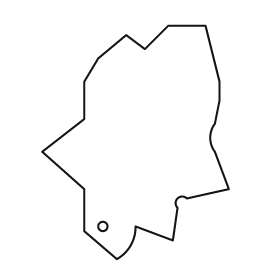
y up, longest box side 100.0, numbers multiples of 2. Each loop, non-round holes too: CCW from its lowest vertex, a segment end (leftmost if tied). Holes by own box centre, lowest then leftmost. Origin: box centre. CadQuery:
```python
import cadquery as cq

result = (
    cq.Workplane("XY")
    .moveTo(-8.0, -50.0)
    .threePointArc((-2.0, -44.0), (0.0, -36.0))
    .lineTo(16.0, -42.0)
    .lineTo(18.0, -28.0)
    .threePointArc((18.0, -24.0), (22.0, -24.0))
    .lineTo(40.0, -20.0)
    .lineTo(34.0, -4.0)
    .threePointArc((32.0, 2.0), (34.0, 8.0))
    .lineTo(36.0, 18.0)
    .lineTo(36.0, 26.0)
    .lineTo(30.0, 50.0)
    .lineTo(14.0, 50.0)
    .lineTo(4.0, 40.0)
    .lineTo(-4.0, 46.0)
    .lineTo(-16.0, 36.0)
    .lineTo(-22.0, 26.0)
    .lineTo(-22.0, 10.0)
    .lineTo(-40.0, -4.0)
    .lineTo(-22.0, -20.0)
    .lineTo(-22.0, -38.0)
    .close()
    .moveTo(-14.0, -36.0)
    .circle(2.0)
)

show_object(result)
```